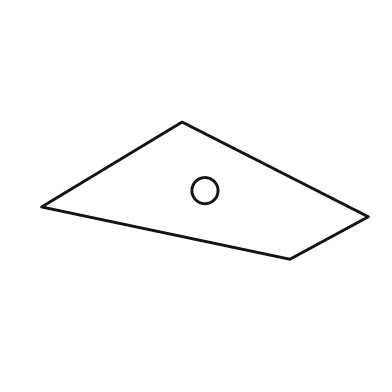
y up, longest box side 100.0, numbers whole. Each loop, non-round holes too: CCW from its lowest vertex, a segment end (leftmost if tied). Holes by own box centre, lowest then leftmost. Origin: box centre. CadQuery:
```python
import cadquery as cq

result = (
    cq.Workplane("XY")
    .moveTo(26.0, -21.0)
    .lineTo(50.0, -8.0)
    .lineTo(-7.0, 21.0)
    .lineTo(-50.0, -5.0)
    .close()
    .moveTo(0.0, 0.0)
    .circle(4.0)
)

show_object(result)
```